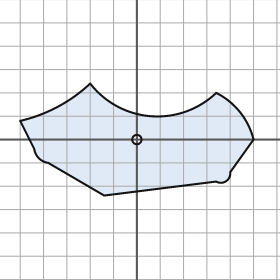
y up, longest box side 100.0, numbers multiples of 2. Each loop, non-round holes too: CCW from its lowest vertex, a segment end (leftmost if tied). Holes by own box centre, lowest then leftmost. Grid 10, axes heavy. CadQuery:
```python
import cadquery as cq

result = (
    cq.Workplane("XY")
    .moveTo(-14.0, -24.0)
    .lineTo(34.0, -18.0)
    .threePointArc((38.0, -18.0), (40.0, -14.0))
    .lineTo(50.0, 0.0)
    .threePointArc((44.0, 12.0), (34.0, 20.0))
    .threePointArc((6.0, 10.0), (-20.0, 24.0))
    .threePointArc((-34.0, 14.0), (-50.0, 8.0))
    .lineTo(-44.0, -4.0)
    .threePointArc((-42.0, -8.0), (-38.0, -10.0))
    .close()
    .moveTo(0.0, 0.0)
    .circle(2.0)
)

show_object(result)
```